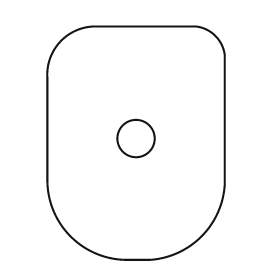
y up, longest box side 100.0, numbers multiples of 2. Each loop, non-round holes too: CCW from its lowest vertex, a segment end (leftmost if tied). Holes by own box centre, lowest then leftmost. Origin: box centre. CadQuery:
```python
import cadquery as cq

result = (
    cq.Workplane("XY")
    .moveTo(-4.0, -50.0)
    .lineTo(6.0, -50.0)
    .threePointArc((28.0, -40.0), (38.0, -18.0))
    .lineTo(38.0, 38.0)
    .threePointArc((34.0, 46.0), (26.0, 50.0))
    .lineTo(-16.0, 50.0)
    .threePointArc((-32.0, 44.0), (-38.0, 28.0))
    .lineTo(-38.0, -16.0)
    .threePointArc((-28.0, -40.0), (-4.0, -50.0))
    .close()
    .moveTo(0.0, 2.0)
    .circle(8.0)
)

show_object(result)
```